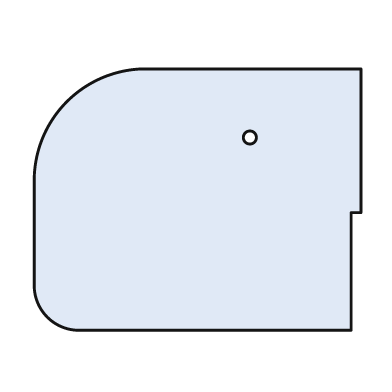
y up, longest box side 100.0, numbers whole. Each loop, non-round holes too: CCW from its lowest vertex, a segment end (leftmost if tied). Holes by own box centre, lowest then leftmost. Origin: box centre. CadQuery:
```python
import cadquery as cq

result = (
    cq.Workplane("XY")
    .moveTo(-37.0, -40.0)
    .lineTo(47.0, -40.0)
    .lineTo(47.0, -4.0)
    .lineTo(50.0, -4.0)
    .lineTo(50.0, 40.0)
    .lineTo(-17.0, 40.0)
    .threePointArc((-40.0, 30.0), (-50.0, 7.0))
    .lineTo(-50.0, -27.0)
    .threePointArc((-46.0, -36.0), (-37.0, -40.0))
    .close()
    .moveTo(16.0, 19.0)
    .circle(2.0)
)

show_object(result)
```